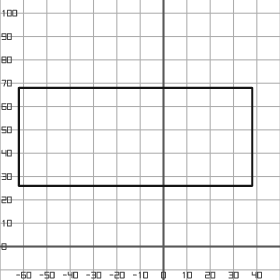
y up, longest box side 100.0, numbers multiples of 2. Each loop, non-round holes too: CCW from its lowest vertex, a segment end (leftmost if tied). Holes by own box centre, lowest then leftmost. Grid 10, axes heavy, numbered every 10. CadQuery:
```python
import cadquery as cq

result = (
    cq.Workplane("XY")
    .moveTo(-62.0, 26.0)
    .lineTo(38.0, 26.0)
    .lineTo(38.0, 68.0)
    .lineTo(-62.0, 68.0)
    .close()
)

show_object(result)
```